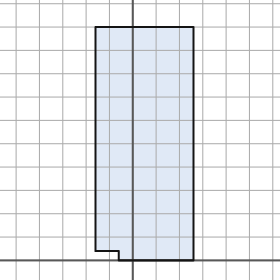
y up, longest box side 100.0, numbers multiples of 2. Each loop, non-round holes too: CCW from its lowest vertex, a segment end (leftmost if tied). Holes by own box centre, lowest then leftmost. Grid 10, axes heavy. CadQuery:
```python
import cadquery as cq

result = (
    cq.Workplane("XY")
    .moveTo(-6.0, 0.0)
    .lineTo(26.0, 0.0)
    .lineTo(26.0, 100.0)
    .lineTo(-16.0, 100.0)
    .lineTo(-16.0, 4.0)
    .lineTo(-6.0, 4.0)
    .close()
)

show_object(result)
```